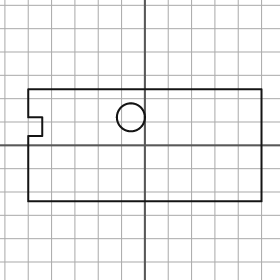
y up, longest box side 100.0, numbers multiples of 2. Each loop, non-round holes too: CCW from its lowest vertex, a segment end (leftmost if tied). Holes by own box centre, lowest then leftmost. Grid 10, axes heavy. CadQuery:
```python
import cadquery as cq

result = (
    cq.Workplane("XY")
    .moveTo(-50.0, -24.0)
    .lineTo(50.0, -24.0)
    .lineTo(50.0, 24.0)
    .lineTo(-50.0, 24.0)
    .lineTo(-50.0, 12.0)
    .lineTo(-44.0, 12.0)
    .lineTo(-44.0, 4.0)
    .lineTo(-50.0, 4.0)
    .close()
    .moveTo(-6.0, 12.0)
    .circle(6.0)
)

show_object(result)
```